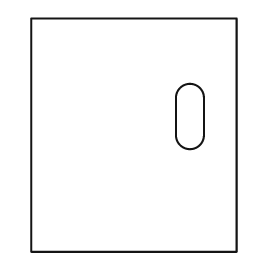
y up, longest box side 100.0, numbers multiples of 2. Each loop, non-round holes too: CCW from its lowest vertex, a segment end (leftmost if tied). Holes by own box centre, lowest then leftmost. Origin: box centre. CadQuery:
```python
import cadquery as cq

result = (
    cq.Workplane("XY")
    .moveTo(-44.0, -50.0)
    .lineTo(44.0, -50.0)
    .lineTo(44.0, 50.0)
    .lineTo(-44.0, 50.0)
    .close()
    .moveTo(18.0, 0.0)
    .threePointArc((24.0, -6.0), (30.0, 0.0))
    .lineTo(30.0, 16.0)
    .threePointArc((24.0, 22.0), (18.0, 16.0))
    .close()
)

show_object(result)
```